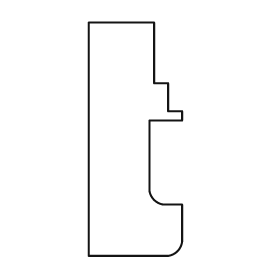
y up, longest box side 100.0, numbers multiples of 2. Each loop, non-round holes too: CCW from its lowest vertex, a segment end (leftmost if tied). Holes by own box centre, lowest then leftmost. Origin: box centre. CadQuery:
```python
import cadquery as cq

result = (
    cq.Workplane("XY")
    .moveTo(-20.0, -50.0)
    .lineTo(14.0, -50.0)
    .threePointArc((18.0, -48.0), (20.0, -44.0))
    .lineTo(20.0, -28.0)
    .lineTo(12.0, -28.0)
    .threePointArc((8.0, -26.0), (6.0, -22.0))
    .lineTo(6.0, 8.0)
    .lineTo(20.0, 8.0)
    .lineTo(20.0, 12.0)
    .lineTo(14.0, 12.0)
    .lineTo(14.0, 24.0)
    .lineTo(8.0, 24.0)
    .lineTo(8.0, 50.0)
    .lineTo(-20.0, 50.0)
    .close()
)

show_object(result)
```